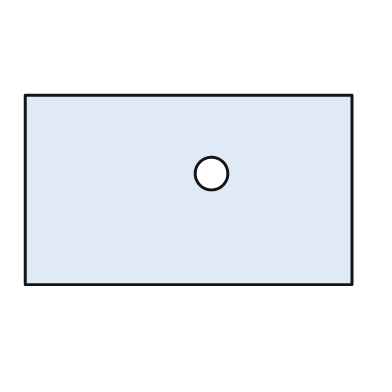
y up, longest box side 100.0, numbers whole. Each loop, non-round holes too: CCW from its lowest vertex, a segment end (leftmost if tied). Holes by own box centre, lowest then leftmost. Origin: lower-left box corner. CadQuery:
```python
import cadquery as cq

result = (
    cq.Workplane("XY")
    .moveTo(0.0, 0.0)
    .lineTo(100.0, 0.0)
    .lineTo(100.0, 58.0)
    .lineTo(0.0, 58.0)
    .close()
    .moveTo(57.0, 34.0)
    .circle(5.0)
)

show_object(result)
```